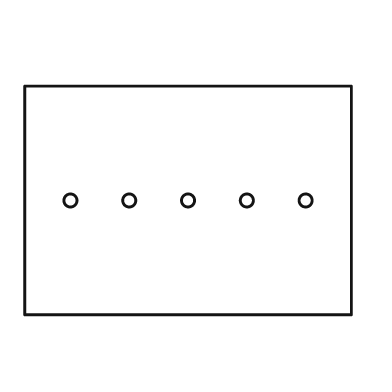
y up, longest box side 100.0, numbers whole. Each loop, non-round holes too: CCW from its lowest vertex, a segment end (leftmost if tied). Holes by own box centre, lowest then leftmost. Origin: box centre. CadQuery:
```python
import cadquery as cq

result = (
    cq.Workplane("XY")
    .moveTo(-50.0, -35.0)
    .lineTo(50.0, -35.0)
    .lineTo(50.0, 35.0)
    .lineTo(-50.0, 35.0)
    .close()
    .moveTo(-36.0, 0.0)
    .circle(2.0)
    .moveTo(-18.0, 0.0)
    .circle(2.0)
    .moveTo(0.0, 0.0)
    .circle(2.0)
    .moveTo(18.0, 0.0)
    .circle(2.0)
    .moveTo(36.0, 0.0)
    .circle(2.0)
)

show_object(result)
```